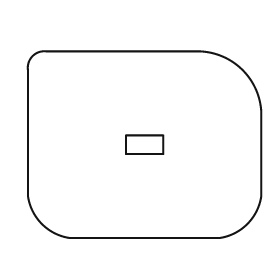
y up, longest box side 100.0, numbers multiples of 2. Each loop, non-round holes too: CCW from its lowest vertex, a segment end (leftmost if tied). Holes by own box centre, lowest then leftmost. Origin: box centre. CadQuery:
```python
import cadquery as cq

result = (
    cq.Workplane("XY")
    .moveTo(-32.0, -40.0)
    .lineTo(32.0, -40.0)
    .threePointArc((44.0, -34.0), (50.0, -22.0))
    .lineTo(50.0, 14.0)
    .threePointArc((42.0, 32.0), (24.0, 40.0))
    .lineTo(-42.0, 40.0)
    .threePointArc((-48.0, 38.0), (-50.0, 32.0))
    .lineTo(-50.0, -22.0)
    .threePointArc((-44.0, -34.0), (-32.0, -40.0))
    .close()
    .moveTo(-8.0, -4.0)
    .lineTo(8.0, -4.0)
    .lineTo(8.0, 4.0)
    .lineTo(-8.0, 4.0)
    .close()
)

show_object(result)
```